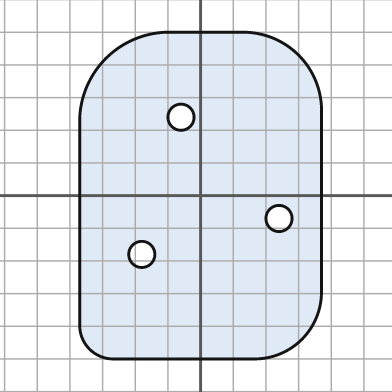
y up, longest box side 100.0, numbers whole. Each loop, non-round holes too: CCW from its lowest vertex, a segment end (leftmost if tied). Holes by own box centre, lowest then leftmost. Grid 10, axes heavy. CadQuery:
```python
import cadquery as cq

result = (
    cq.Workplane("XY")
    .moveTo(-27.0, -50.0)
    .lineTo(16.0, -50.0)
    .threePointArc((31.0, -44.0), (37.0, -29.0))
    .lineTo(37.0, 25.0)
    .threePointArc((30.0, 43.0), (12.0, 50.0))
    .lineTo(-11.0, 50.0)
    .threePointArc((-29.0, 42.0), (-37.0, 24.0))
    .lineTo(-37.0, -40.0)
    .threePointArc((-34.0, -47.0), (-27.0, -50.0))
    .close()
    .moveTo(-18.0, -18.0)
    .circle(4.0)
    .moveTo(24.0, -7.0)
    .circle(4.0)
    .moveTo(-6.0, 24.0)
    .circle(4.0)
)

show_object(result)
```